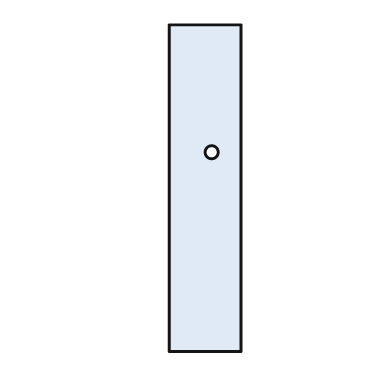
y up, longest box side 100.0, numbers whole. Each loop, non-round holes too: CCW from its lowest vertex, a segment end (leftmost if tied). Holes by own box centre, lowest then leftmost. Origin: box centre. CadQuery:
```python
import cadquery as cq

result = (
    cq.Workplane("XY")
    .moveTo(-11.0, -50.0)
    .lineTo(11.0, -50.0)
    .lineTo(11.0, 50.0)
    .lineTo(-11.0, 50.0)
    .close()
    .moveTo(2.0, 11.0)
    .circle(2.0)
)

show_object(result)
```